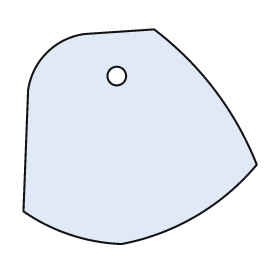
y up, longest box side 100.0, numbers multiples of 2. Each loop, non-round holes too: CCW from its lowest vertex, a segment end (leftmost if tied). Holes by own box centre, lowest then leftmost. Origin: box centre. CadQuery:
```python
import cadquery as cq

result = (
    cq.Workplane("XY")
    .moveTo(-8.0, -46.0)
    .threePointArc((24.0, -34.0), (50.0, -12.0))
    .threePointArc((32.0, 20.0), (6.0, 46.0))
    .lineTo(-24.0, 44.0)
    .threePointArc((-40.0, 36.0), (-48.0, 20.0))
    .lineTo(-50.0, -32.0)
    .threePointArc((-30.0, -42.0), (-8.0, -46.0))
    .close()
    .moveTo(-10.0, 26.0)
    .circle(4.0)
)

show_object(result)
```